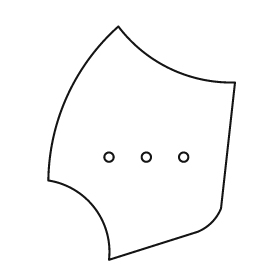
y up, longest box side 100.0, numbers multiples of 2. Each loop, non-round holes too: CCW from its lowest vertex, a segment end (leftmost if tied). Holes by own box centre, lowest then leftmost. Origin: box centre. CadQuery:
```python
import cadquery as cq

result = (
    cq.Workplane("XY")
    .moveTo(-14.0, -50.0)
    .lineTo(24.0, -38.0)
    .threePointArc((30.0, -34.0), (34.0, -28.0))
    .lineTo(40.0, 26.0)
    .threePointArc((12.0, 32.0), (-10.0, 50.0))
    .threePointArc((-32.0, 20.0), (-40.0, -16.0))
    .threePointArc((-20.0, -28.0), (-14.0, -50.0))
    .close()
    .moveTo(-14.0, -6.0)
    .circle(2.0)
    .moveTo(2.0, -6.0)
    .circle(2.0)
    .moveTo(18.0, -6.0)
    .circle(2.0)
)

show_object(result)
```